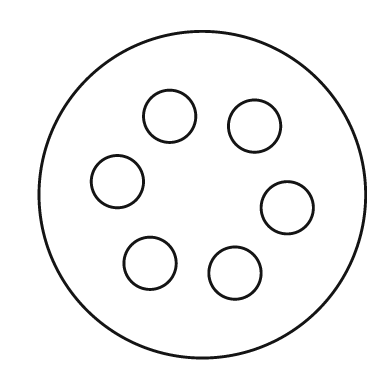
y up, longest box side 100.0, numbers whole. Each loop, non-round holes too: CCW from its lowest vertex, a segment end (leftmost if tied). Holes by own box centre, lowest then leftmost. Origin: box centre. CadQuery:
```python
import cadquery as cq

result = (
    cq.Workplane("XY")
    .moveTo(0.0, 0.0)
    .circle(50.0)
    .moveTo(10.0, -24.0)
    .circle(8.0)
    .moveTo(-16.0, -21.0)
    .circle(8.0)
    .moveTo(26.0, -4.0)
    .circle(8.0)
    .moveTo(-26.0, 4.0)
    .circle(8.0)
    .moveTo(16.0, 21.0)
    .circle(8.0)
    .moveTo(-10.0, 24.0)
    .circle(8.0)
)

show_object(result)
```